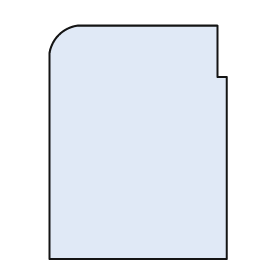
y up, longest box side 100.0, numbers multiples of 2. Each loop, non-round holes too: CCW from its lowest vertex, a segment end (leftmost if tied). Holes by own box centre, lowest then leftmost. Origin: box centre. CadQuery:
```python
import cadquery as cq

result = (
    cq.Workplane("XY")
    .moveTo(-38.0, -50.0)
    .lineTo(38.0, -50.0)
    .lineTo(38.0, 28.0)
    .lineTo(34.0, 28.0)
    .lineTo(34.0, 50.0)
    .lineTo(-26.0, 50.0)
    .threePointArc((-34.0, 46.0), (-38.0, 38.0))
    .close()
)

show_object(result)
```